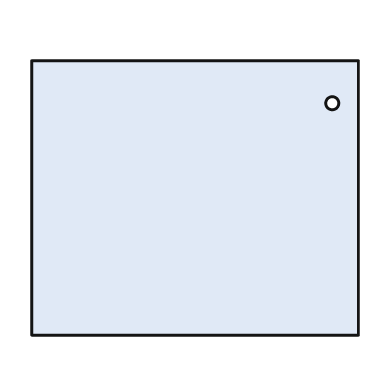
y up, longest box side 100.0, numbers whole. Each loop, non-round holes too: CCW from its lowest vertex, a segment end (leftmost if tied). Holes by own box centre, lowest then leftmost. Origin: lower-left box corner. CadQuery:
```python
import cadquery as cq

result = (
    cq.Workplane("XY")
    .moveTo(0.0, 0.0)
    .lineTo(100.0, 0.0)
    .lineTo(100.0, 84.0)
    .lineTo(0.0, 84.0)
    .close()
    .moveTo(92.0, 71.0)
    .circle(2.0)
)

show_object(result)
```